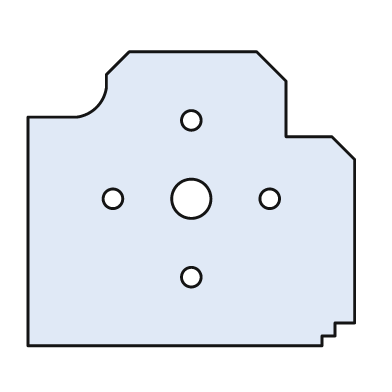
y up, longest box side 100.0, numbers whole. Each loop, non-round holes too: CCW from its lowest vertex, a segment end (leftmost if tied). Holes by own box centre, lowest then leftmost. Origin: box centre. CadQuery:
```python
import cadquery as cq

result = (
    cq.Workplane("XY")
    .moveTo(-50.0, -45.0)
    .lineTo(40.0, -45.0)
    .lineTo(40.0, -42.0)
    .lineTo(44.0, -42.0)
    .lineTo(44.0, -38.0)
    .lineTo(50.0, -38.0)
    .lineTo(50.0, 12.0)
    .lineTo(43.0, 19.0)
    .lineTo(29.0, 19.0)
    .lineTo(29.0, 36.0)
    .lineTo(20.0, 45.0)
    .lineTo(-19.0, 45.0)
    .lineTo(-26.0, 38.0)
    .lineTo(-26.0, 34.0)
    .threePointArc((-29.0, 28.0), (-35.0, 25.0))
    .lineTo(-50.0, 25.0)
    .close()
    .moveTo(0.0, -24.0)
    .circle(3.0)
    .moveTo(-24.0, 0.0)
    .circle(3.0)
    .moveTo(0.0, 0.0)
    .circle(6.0)
    .moveTo(24.0, 0.0)
    .circle(3.0)
    .moveTo(0.0, 24.0)
    .circle(3.0)
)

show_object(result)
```